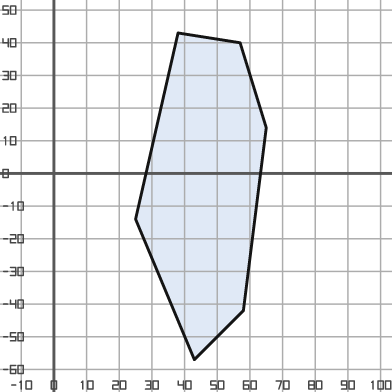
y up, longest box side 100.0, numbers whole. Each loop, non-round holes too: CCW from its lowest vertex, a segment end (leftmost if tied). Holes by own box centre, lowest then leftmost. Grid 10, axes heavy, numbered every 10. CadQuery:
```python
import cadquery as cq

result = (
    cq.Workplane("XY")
    .moveTo(43.0, -57.0)
    .lineTo(58.0, -42.0)
    .lineTo(65.0, 14.0)
    .lineTo(57.0, 40.0)
    .lineTo(38.0, 43.0)
    .lineTo(25.0, -14.0)
    .close()
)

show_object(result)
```